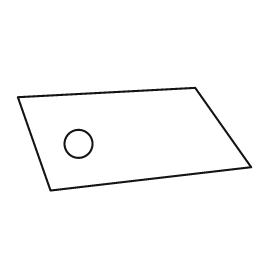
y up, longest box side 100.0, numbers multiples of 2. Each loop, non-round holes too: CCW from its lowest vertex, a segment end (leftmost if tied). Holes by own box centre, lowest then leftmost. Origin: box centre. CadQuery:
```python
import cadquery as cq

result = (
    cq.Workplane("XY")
    .moveTo(-36.0, -22.0)
    .lineTo(50.0, -12.0)
    .lineTo(26.0, 22.0)
    .lineTo(-50.0, 18.0)
    .close()
    .moveTo(-24.0, -2.0)
    .circle(6.0)
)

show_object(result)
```